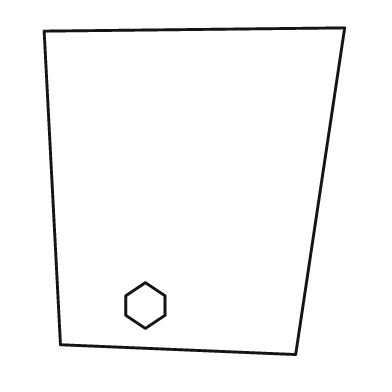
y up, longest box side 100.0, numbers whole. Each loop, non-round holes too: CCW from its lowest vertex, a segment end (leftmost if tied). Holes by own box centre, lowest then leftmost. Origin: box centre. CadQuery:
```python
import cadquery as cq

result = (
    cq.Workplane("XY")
    .moveTo(31.0, -50.0)
    .lineTo(46.0, 50.0)
    .lineTo(-46.0, 49.0)
    .lineTo(-41.0, -47.0)
    .close()
    .moveTo(-15.0, -42.0)
    .lineTo(-9.0, -38.0)
    .lineTo(-9.0, -32.0)
    .lineTo(-15.0, -28.0)
    .lineTo(-21.0, -32.0)
    .lineTo(-21.0, -38.0)
    .close()
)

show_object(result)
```